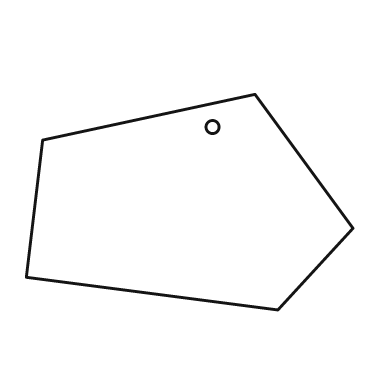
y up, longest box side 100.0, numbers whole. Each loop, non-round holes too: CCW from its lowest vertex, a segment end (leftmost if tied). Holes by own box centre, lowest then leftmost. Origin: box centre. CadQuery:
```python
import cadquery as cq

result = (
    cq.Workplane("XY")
    .moveTo(27.0, -33.0)
    .lineTo(50.0, -8.0)
    .lineTo(20.0, 33.0)
    .lineTo(-45.0, 19.0)
    .lineTo(-50.0, -23.0)
    .close()
    .moveTo(7.0, 23.0)
    .circle(2.0)
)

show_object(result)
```